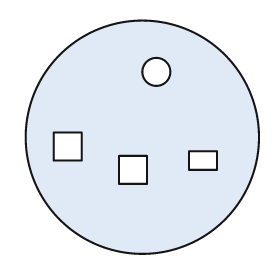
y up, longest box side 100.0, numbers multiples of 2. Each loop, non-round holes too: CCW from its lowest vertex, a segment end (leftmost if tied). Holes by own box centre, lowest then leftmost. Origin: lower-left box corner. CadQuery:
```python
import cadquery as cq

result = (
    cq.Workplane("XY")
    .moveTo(50.0, 50.0)
    .circle(50.0)
    .moveTo(40.0, 30.0)
    .lineTo(52.0, 30.0)
    .lineTo(52.0, 42.0)
    .lineTo(40.0, 42.0)
    .close()
    .moveTo(70.0, 36.0)
    .lineTo(82.0, 36.0)
    .lineTo(82.0, 44.0)
    .lineTo(70.0, 44.0)
    .close()
    .moveTo(12.0, 40.0)
    .lineTo(24.0, 40.0)
    .lineTo(24.0, 52.0)
    .lineTo(12.0, 52.0)
    .close()
    .moveTo(56.0, 78.0)
    .circle(6.0)
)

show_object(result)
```